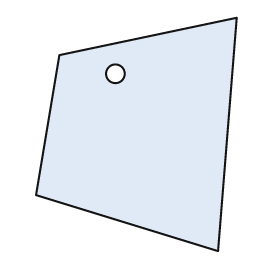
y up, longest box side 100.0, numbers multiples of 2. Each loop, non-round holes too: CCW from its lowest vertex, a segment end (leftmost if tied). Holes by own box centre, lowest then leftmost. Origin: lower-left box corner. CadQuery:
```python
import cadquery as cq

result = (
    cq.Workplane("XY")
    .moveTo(78.0, 0.0)
    .lineTo(86.0, 100.0)
    .lineTo(10.0, 84.0)
    .lineTo(0.0, 24.0)
    .close()
    .moveTo(34.0, 76.0)
    .circle(4.0)
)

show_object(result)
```